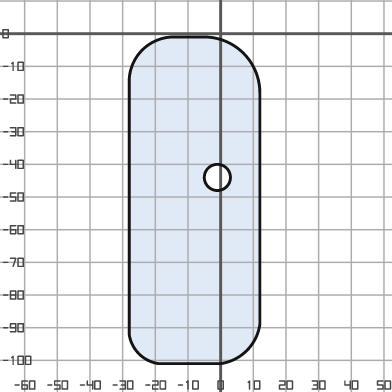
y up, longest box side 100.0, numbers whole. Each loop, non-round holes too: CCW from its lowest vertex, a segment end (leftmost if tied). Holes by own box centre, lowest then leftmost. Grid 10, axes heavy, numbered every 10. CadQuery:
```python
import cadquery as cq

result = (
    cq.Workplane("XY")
    .moveTo(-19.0, -101.0)
    .lineTo(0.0, -101.0)
    .threePointArc((8.0, -97.0), (12.0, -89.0))
    .lineTo(12.0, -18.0)
    .threePointArc((7.0, -6.0), (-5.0, -1.0))
    .lineTo(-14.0, -1.0)
    .threePointArc((-24.0, -5.0), (-28.0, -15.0))
    .lineTo(-28.0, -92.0)
    .threePointArc((-25.0, -98.0), (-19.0, -101.0))
    .close()
    .moveTo(-1.0, -44.0)
    .circle(4.0)
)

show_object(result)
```